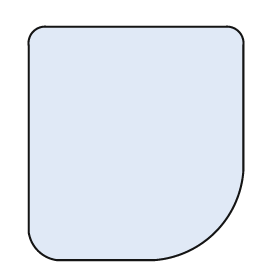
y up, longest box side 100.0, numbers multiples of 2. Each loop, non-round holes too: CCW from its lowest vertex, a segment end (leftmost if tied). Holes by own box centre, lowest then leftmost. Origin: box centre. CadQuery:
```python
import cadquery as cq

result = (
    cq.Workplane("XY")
    .moveTo(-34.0, -50.0)
    .lineTo(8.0, -50.0)
    .threePointArc((34.0, -38.0), (46.0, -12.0))
    .lineTo(46.0, 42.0)
    .threePointArc((44.0, 48.0), (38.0, 50.0))
    .lineTo(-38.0, 50.0)
    .threePointArc((-44.0, 48.0), (-46.0, 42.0))
    .lineTo(-46.0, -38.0)
    .threePointArc((-42.0, -46.0), (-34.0, -50.0))
    .close()
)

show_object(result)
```